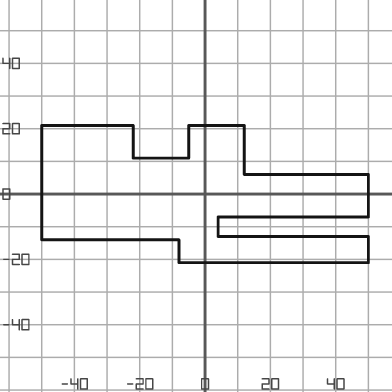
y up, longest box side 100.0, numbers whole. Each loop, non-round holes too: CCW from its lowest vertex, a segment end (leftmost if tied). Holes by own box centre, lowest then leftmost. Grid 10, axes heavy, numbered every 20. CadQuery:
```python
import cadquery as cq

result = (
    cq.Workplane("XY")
    .moveTo(-8.0, -21.0)
    .lineTo(50.0, -21.0)
    .lineTo(50.0, -13.0)
    .lineTo(4.0, -13.0)
    .lineTo(4.0, -7.0)
    .lineTo(50.0, -7.0)
    .lineTo(50.0, 6.0)
    .lineTo(12.0, 6.0)
    .lineTo(12.0, 21.0)
    .lineTo(-5.0, 21.0)
    .lineTo(-5.0, 11.0)
    .lineTo(-22.0, 11.0)
    .lineTo(-22.0, 21.0)
    .lineTo(-50.0, 21.0)
    .lineTo(-50.0, -14.0)
    .lineTo(-8.0, -14.0)
    .close()
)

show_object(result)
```